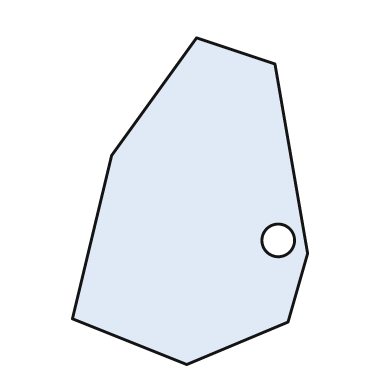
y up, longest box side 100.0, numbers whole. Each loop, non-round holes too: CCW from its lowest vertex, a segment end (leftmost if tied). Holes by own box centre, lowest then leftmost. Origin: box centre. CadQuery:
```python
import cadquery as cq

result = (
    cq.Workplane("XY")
    .moveTo(-1.0, -50.0)
    .lineTo(30.0, -37.0)
    .lineTo(36.0, -16.0)
    .lineTo(26.0, 42.0)
    .lineTo(2.0, 50.0)
    .lineTo(-24.0, 14.0)
    .lineTo(-36.0, -36.0)
    .close()
    .moveTo(27.0, -12.0)
    .circle(5.0)
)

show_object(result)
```